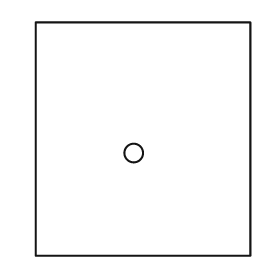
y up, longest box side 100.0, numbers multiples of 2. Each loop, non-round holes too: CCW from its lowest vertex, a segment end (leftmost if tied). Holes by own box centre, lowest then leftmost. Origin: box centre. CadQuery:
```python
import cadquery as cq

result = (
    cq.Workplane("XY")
    .moveTo(-46.0, -50.0)
    .lineTo(46.0, -50.0)
    .lineTo(46.0, 50.0)
    .lineTo(-46.0, 50.0)
    .close()
    .moveTo(-4.0, -6.0)
    .circle(4.0)
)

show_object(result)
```